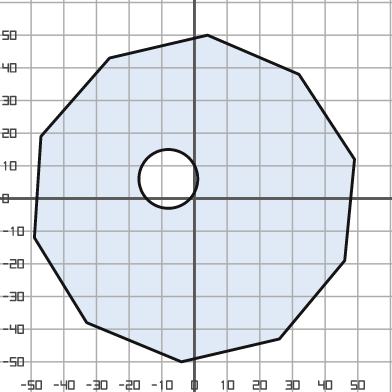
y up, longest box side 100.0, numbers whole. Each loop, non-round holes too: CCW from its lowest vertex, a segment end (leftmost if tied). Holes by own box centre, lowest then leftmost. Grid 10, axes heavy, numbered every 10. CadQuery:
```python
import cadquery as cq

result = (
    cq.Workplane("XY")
    .moveTo(-4.0, -50.0)
    .lineTo(26.0, -43.0)
    .lineTo(46.0, -19.0)
    .lineTo(49.0, 12.0)
    .lineTo(32.0, 38.0)
    .lineTo(4.0, 50.0)
    .lineTo(-26.0, 43.0)
    .lineTo(-47.0, 19.0)
    .lineTo(-49.0, -12.0)
    .lineTo(-33.0, -38.0)
    .close()
    .moveTo(-8.0, 6.0)
    .circle(9.0)
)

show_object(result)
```